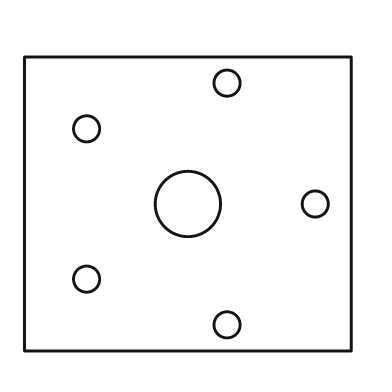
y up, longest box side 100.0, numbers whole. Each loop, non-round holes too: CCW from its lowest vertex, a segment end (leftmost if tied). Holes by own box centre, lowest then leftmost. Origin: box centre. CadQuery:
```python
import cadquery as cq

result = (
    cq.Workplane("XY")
    .moveTo(-50.0, -45.0)
    .lineTo(50.0, -45.0)
    .lineTo(50.0, 45.0)
    .lineTo(-50.0, 45.0)
    .close()
    .moveTo(12.0, -37.0)
    .circle(4.0)
    .moveTo(-31.0, -23.0)
    .circle(4.0)
    .moveTo(0.0, 0.0)
    .circle(10.0)
    .moveTo(39.0, 0.0)
    .circle(4.0)
    .moveTo(-31.0, 23.0)
    .circle(4.0)
    .moveTo(12.0, 37.0)
    .circle(4.0)
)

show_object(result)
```